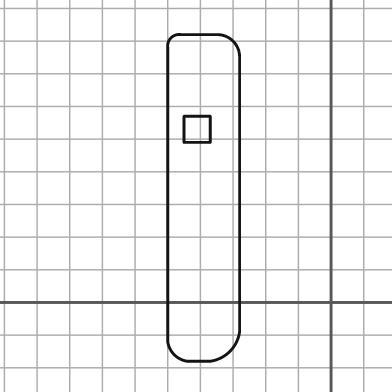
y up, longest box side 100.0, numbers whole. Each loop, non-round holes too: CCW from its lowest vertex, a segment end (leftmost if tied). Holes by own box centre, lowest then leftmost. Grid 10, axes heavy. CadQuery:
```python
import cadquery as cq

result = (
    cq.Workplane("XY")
    .moveTo(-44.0, -18.0)
    .lineTo(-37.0, -18.0)
    .threePointArc((-31.0, -15.0), (-28.0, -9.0))
    .lineTo(-28.0, 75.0)
    .threePointArc((-30.0, 80.0), (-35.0, 82.0))
    .lineTo(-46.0, 82.0)
    .threePointArc((-49.0, 81.0), (-50.0, 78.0))
    .lineTo(-50.0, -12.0)
    .threePointArc((-48.0, -16.0), (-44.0, -18.0))
    .close()
    .moveTo(-45.0, 49.0)
    .lineTo(-37.0, 49.0)
    .lineTo(-37.0, 57.0)
    .lineTo(-45.0, 57.0)
    .close()
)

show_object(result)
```